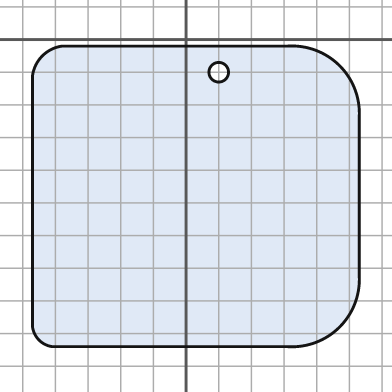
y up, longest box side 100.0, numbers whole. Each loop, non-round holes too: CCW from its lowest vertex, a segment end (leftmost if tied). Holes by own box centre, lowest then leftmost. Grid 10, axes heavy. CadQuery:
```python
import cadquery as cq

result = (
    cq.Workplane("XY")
    .moveTo(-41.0, -94.0)
    .lineTo(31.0, -94.0)
    .threePointArc((47.0, -88.0), (53.0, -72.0))
    .lineTo(53.0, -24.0)
    .threePointArc((47.0, -8.0), (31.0, -2.0))
    .lineTo(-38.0, -2.0)
    .threePointArc((-44.0, -5.0), (-47.0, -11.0))
    .lineTo(-47.0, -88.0)
    .threePointArc((-45.0, -92.0), (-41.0, -94.0))
    .close()
    .moveTo(10.0, -10.0)
    .circle(3.0)
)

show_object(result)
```